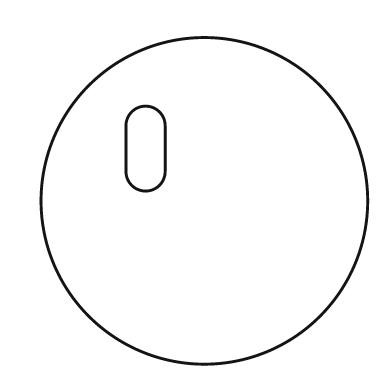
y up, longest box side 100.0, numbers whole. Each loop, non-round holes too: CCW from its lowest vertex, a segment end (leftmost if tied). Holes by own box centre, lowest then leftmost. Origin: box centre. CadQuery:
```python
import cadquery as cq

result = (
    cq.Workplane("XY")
    .moveTo(0.0, 0.0)
    .circle(50.0)
    .moveTo(-24.0, 9.0)
    .threePointArc((-18.0, 3.0), (-12.0, 9.0))
    .lineTo(-12.0, 23.0)
    .threePointArc((-18.0, 29.0), (-24.0, 23.0))
    .close()
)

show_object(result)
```